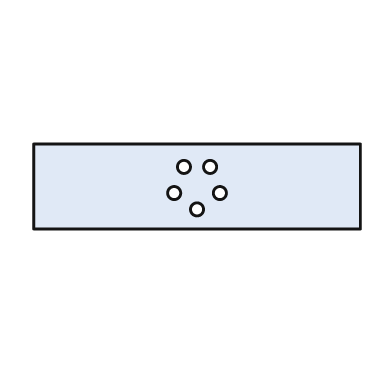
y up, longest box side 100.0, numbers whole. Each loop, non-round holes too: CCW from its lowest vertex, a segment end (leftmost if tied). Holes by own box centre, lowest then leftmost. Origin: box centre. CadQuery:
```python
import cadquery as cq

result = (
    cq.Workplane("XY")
    .moveTo(-50.0, -13.0)
    .lineTo(50.0, -13.0)
    .lineTo(50.0, 13.0)
    .lineTo(-50.0, 13.0)
    .close()
    .moveTo(0.0, -7.0)
    .circle(2.0)
    .moveTo(-7.0, -2.0)
    .circle(2.0)
    .moveTo(7.0, -2.0)
    .circle(2.0)
    .moveTo(-4.0, 6.0)
    .circle(2.0)
    .moveTo(4.0, 6.0)
    .circle(2.0)
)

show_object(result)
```